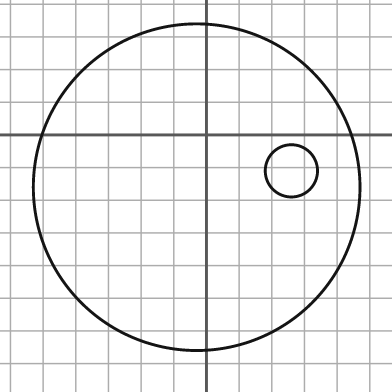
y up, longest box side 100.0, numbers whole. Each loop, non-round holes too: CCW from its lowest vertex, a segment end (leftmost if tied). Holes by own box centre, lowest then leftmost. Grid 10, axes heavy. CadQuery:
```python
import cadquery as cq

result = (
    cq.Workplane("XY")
    .moveTo(-3.0, -16.0)
    .circle(50.0)
    .moveTo(26.0, -11.0)
    .circle(8.0)
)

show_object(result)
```